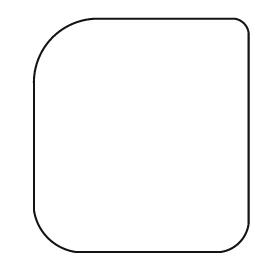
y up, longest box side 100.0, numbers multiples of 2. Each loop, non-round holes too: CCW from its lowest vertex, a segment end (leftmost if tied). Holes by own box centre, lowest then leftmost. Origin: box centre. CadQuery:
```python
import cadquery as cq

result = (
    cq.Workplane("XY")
    .moveTo(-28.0, -50.0)
    .lineTo(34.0, -50.0)
    .threePointArc((42.0, -46.0), (46.0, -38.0))
    .lineTo(46.0, 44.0)
    .threePointArc((44.0, 48.0), (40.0, 50.0))
    .lineTo(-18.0, 50.0)
    .threePointArc((-38.0, 42.0), (-46.0, 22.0))
    .lineTo(-46.0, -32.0)
    .threePointArc((-40.0, -44.0), (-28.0, -50.0))
    .close()
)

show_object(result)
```